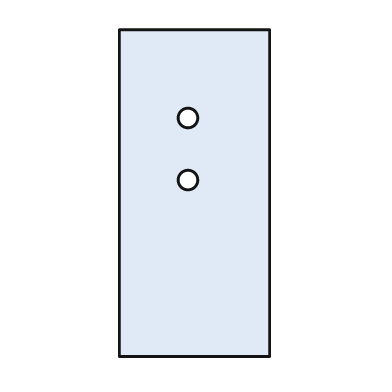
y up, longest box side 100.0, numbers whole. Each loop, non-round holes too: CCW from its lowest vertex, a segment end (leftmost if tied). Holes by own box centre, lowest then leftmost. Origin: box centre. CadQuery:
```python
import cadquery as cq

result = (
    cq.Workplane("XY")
    .moveTo(-23.0, -50.0)
    .lineTo(23.0, -50.0)
    .lineTo(23.0, 50.0)
    .lineTo(-23.0, 50.0)
    .close()
    .moveTo(-2.0, 4.0)
    .circle(3.0)
    .moveTo(-2.0, 23.0)
    .circle(3.0)
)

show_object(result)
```